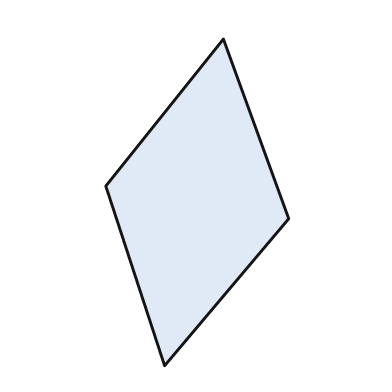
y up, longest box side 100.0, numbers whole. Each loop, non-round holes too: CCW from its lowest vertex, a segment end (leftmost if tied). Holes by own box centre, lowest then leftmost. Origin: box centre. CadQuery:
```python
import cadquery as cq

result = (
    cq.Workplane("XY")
    .moveTo(-10.0, -50.0)
    .lineTo(28.0, -5.0)
    .lineTo(8.0, 50.0)
    .lineTo(-28.0, 5.0)
    .close()
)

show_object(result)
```